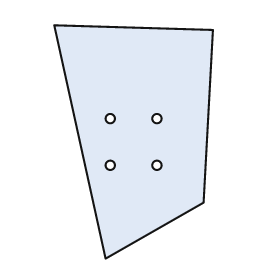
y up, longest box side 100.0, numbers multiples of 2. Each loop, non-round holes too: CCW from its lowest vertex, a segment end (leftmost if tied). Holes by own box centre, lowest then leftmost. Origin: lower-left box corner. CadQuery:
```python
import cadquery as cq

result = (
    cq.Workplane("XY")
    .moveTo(22.0, 0.0)
    .lineTo(64.0, 24.0)
    .lineTo(68.0, 98.0)
    .lineTo(0.0, 100.0)
    .close()
    .moveTo(24.0, 40.0)
    .circle(2.0)
    .moveTo(44.0, 40.0)
    .circle(2.0)
    .moveTo(24.0, 60.0)
    .circle(2.0)
    .moveTo(44.0, 60.0)
    .circle(2.0)
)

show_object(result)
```